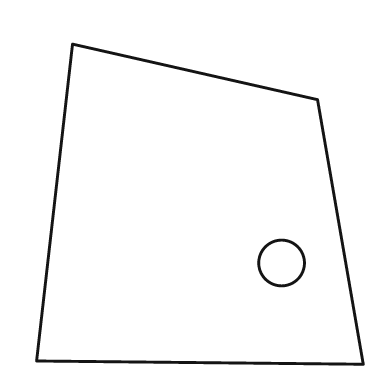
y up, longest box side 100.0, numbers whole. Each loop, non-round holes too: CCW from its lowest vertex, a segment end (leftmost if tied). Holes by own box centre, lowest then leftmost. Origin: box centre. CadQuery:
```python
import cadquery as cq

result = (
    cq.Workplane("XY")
    .moveTo(50.0, -49.0)
    .lineTo(36.0, 32.0)
    .lineTo(-39.0, 49.0)
    .lineTo(-50.0, -48.0)
    .close()
    .moveTo(25.0, -18.0)
    .circle(7.0)
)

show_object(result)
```